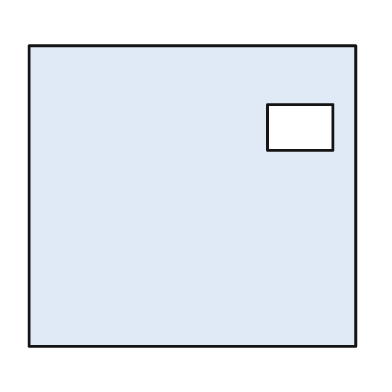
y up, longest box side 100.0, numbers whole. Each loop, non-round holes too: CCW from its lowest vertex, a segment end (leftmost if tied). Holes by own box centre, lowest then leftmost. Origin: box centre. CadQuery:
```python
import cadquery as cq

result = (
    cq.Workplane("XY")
    .moveTo(-50.0, -46.0)
    .lineTo(50.0, -46.0)
    .lineTo(50.0, 46.0)
    .lineTo(-50.0, 46.0)
    .close()
    .moveTo(23.0, 14.0)
    .lineTo(43.0, 14.0)
    .lineTo(43.0, 28.0)
    .lineTo(23.0, 28.0)
    .close()
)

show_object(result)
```